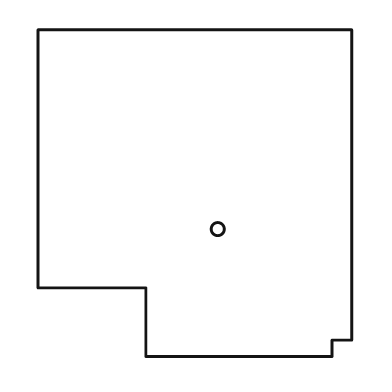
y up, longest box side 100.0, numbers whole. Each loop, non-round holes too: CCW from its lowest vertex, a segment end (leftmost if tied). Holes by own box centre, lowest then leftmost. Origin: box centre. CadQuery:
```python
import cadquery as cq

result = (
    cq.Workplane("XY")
    .moveTo(-15.0, -50.0)
    .lineTo(42.0, -50.0)
    .lineTo(42.0, -45.0)
    .lineTo(48.0, -45.0)
    .lineTo(48.0, 50.0)
    .lineTo(-48.0, 50.0)
    .lineTo(-48.0, -29.0)
    .lineTo(-15.0, -29.0)
    .close()
    .moveTo(7.0, -11.0)
    .circle(2.0)
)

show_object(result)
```